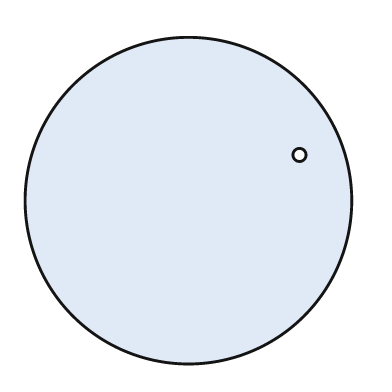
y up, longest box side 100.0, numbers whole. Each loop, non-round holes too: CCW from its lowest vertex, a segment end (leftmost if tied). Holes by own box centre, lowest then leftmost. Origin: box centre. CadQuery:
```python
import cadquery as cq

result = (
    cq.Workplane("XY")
    .moveTo(0.0, 0.0)
    .circle(50.0)
    .moveTo(34.0, 14.0)
    .circle(2.0)
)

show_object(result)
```